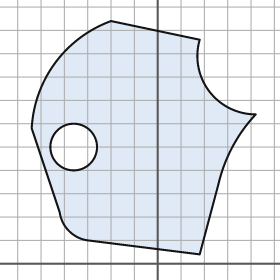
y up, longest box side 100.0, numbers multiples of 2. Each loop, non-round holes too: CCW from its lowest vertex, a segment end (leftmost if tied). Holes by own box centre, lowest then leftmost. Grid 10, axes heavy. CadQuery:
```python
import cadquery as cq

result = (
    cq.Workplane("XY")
    .moveTo(18.0, 4.0)
    .lineTo(26.0, 34.0)
    .threePointArc((32.0, 50.0), (42.0, 64.0))
    .threePointArc((22.0, 74.0), (18.0, 96.0))
    .lineTo(-20.0, 104.0)
    .threePointArc((-44.0, 86.0), (-54.0, 58.0))
    .lineTo(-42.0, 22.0)
    .threePointArc((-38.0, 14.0), (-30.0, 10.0))
    .close()
    .moveTo(-36.0, 50.0)
    .circle(10.0)
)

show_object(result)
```